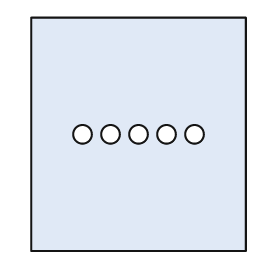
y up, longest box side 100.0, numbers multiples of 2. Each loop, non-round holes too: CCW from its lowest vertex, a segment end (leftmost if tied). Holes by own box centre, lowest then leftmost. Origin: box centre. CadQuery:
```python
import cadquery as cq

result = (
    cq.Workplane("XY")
    .moveTo(-46.0, -50.0)
    .lineTo(46.0, -50.0)
    .lineTo(46.0, 50.0)
    .lineTo(-46.0, 50.0)
    .close()
    .moveTo(-24.0, 0.0)
    .circle(4.0)
    .moveTo(-12.0, 0.0)
    .circle(4.0)
    .moveTo(0.0, 0.0)
    .circle(4.0)
    .moveTo(12.0, 0.0)
    .circle(4.0)
    .moveTo(24.0, 0.0)
    .circle(4.0)
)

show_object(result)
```